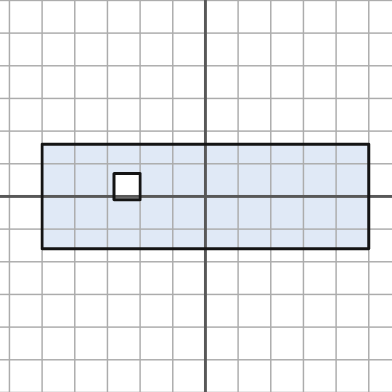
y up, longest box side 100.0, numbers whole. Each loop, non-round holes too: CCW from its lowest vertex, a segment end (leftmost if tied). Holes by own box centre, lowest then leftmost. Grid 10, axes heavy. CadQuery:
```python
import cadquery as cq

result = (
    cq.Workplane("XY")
    .moveTo(-50.0, -16.0)
    .lineTo(50.0, -16.0)
    .lineTo(50.0, 16.0)
    .lineTo(-50.0, 16.0)
    .close()
    .moveTo(-28.0, -1.0)
    .lineTo(-20.0, -1.0)
    .lineTo(-20.0, 7.0)
    .lineTo(-28.0, 7.0)
    .close()
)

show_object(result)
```